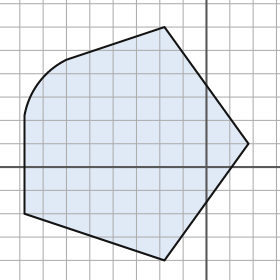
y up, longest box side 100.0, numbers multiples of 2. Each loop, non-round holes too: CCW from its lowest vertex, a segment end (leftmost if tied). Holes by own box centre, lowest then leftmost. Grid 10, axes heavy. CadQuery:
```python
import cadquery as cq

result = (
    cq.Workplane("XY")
    .moveTo(-18.0, -40.0)
    .lineTo(18.0, 10.0)
    .lineTo(-18.0, 60.0)
    .lineTo(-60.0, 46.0)
    .threePointArc((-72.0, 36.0), (-78.0, 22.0))
    .lineTo(-78.0, -20.0)
    .close()
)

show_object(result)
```